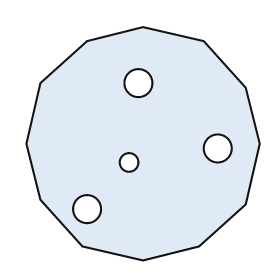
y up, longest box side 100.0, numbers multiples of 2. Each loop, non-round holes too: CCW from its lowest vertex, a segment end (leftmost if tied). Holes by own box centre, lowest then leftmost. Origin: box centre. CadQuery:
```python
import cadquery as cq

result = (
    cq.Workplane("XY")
    .moveTo(0.0, -50.0)
    .lineTo(24.0, -44.0)
    .lineTo(44.0, -26.0)
    .lineTo(50.0, 0.0)
    .lineTo(44.0, 24.0)
    .lineTo(26.0, 44.0)
    .lineTo(0.0, 50.0)
    .lineTo(-24.0, 44.0)
    .lineTo(-44.0, 26.0)
    .lineTo(-50.0, 0.0)
    .lineTo(-44.0, -24.0)
    .lineTo(-26.0, -44.0)
    .close()
    .moveTo(-24.0, -28.0)
    .circle(6.0)
    .moveTo(-6.0, -8.0)
    .circle(4.0)
    .moveTo(32.0, -2.0)
    .circle(6.0)
    .moveTo(-2.0, 26.0)
    .circle(6.0)
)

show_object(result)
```